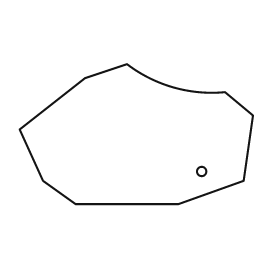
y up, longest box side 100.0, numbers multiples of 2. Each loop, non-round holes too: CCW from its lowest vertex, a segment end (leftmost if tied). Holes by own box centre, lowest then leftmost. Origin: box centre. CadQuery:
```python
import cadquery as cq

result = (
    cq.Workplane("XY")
    .moveTo(-26.0, -30.0)
    .lineTo(18.0, -30.0)
    .lineTo(46.0, -20.0)
    .lineTo(50.0, 8.0)
    .lineTo(38.0, 18.0)
    .threePointArc((16.0, 20.0), (-4.0, 30.0))
    .lineTo(-22.0, 24.0)
    .lineTo(-50.0, 2.0)
    .lineTo(-40.0, -20.0)
    .close()
    .moveTo(28.0, -16.0)
    .circle(2.0)
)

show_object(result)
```